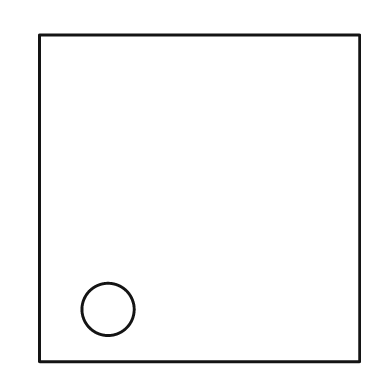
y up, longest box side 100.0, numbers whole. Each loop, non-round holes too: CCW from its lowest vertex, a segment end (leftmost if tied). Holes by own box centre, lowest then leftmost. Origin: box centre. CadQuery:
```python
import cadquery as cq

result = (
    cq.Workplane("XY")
    .moveTo(-49.0, -50.0)
    .lineTo(49.0, -50.0)
    .lineTo(49.0, 50.0)
    .lineTo(-49.0, 50.0)
    .close()
    .moveTo(-28.0, -34.0)
    .circle(8.0)
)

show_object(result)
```